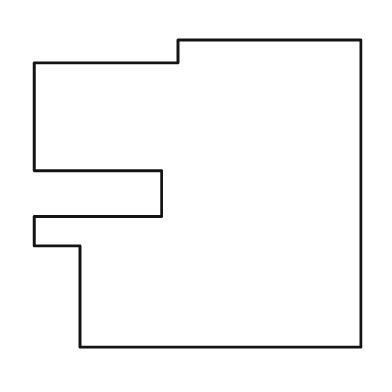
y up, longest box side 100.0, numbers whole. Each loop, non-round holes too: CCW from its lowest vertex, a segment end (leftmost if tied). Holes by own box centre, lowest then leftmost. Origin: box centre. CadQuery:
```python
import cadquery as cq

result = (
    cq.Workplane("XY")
    .moveTo(-36.0, -47.0)
    .lineTo(50.0, -47.0)
    .lineTo(50.0, 47.0)
    .lineTo(-6.0, 47.0)
    .lineTo(-6.0, 40.0)
    .lineTo(-50.0, 40.0)
    .lineTo(-50.0, 7.0)
    .lineTo(-11.0, 7.0)
    .lineTo(-11.0, -7.0)
    .lineTo(-50.0, -7.0)
    .lineTo(-50.0, -16.0)
    .lineTo(-36.0, -16.0)
    .close()
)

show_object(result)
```